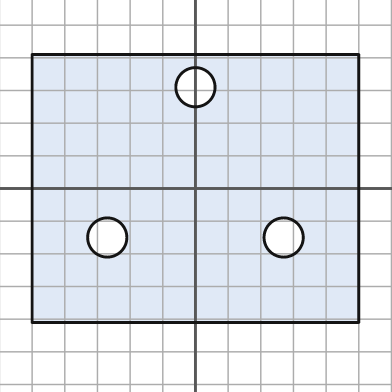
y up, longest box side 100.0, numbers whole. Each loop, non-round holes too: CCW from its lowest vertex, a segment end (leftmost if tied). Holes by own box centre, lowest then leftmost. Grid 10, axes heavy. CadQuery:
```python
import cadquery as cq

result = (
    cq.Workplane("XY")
    .moveTo(-50.0, -41.0)
    .lineTo(50.0, -41.0)
    .lineTo(50.0, 41.0)
    .lineTo(-50.0, 41.0)
    .close()
    .moveTo(-27.0, -15.0)
    .circle(6.0)
    .moveTo(27.0, -15.0)
    .circle(6.0)
    .moveTo(0.0, 31.0)
    .circle(6.0)
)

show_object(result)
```